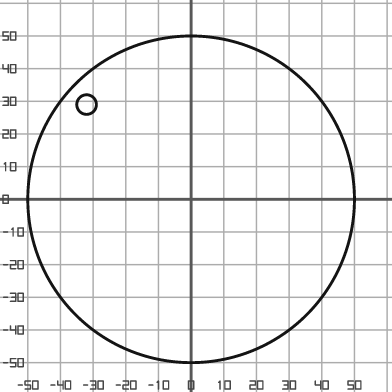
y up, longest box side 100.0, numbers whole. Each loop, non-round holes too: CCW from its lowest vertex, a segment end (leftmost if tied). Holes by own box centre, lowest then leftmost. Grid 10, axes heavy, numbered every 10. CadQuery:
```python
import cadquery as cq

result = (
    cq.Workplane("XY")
    .moveTo(0.0, 0.0)
    .circle(50.0)
    .moveTo(-32.0, 29.0)
    .circle(3.0)
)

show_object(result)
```